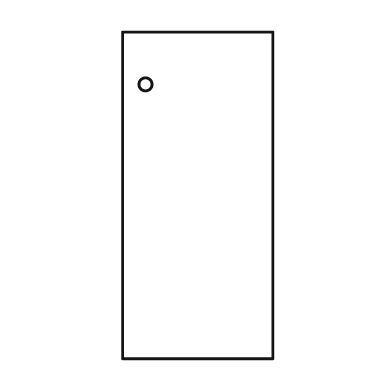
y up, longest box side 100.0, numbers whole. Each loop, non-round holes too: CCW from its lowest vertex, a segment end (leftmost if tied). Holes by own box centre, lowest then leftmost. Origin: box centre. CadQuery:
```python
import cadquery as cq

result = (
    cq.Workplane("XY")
    .moveTo(-23.0, -50.0)
    .lineTo(23.0, -50.0)
    .lineTo(23.0, 50.0)
    .lineTo(-23.0, 50.0)
    .close()
    .moveTo(-16.0, 34.0)
    .circle(2.0)
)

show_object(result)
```